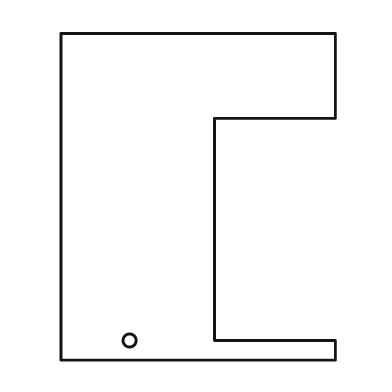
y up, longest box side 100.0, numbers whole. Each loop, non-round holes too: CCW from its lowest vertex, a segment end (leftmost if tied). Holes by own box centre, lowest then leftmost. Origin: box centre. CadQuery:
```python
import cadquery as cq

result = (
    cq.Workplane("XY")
    .moveTo(-42.0, -50.0)
    .lineTo(42.0, -50.0)
    .lineTo(42.0, -44.0)
    .lineTo(5.0, -44.0)
    .lineTo(5.0, 24.0)
    .lineTo(42.0, 24.0)
    .lineTo(42.0, 50.0)
    .lineTo(-42.0, 50.0)
    .close()
    .moveTo(-21.0, -44.0)
    .circle(2.0)
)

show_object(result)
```